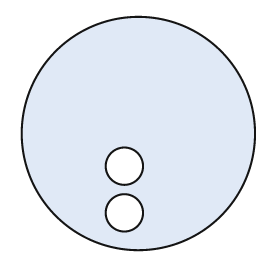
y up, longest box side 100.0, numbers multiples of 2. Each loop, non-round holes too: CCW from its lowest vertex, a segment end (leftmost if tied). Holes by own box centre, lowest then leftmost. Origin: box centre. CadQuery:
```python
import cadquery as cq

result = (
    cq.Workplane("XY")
    .moveTo(0.0, 0.0)
    .circle(50.0)
    .moveTo(-6.0, -34.0)
    .circle(8.0)
    .moveTo(-6.0, -14.0)
    .circle(8.0)
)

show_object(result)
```